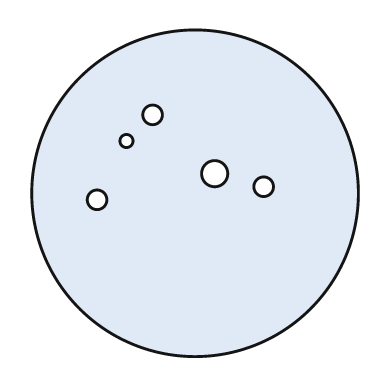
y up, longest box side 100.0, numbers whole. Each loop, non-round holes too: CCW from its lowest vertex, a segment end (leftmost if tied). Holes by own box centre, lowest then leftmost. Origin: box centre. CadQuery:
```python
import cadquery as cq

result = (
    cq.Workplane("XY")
    .moveTo(0.0, 0.0)
    .circle(50.0)
    .moveTo(-30.0, -2.0)
    .circle(3.0)
    .moveTo(21.0, 2.0)
    .circle(3.0)
    .moveTo(6.0, 6.0)
    .circle(4.0)
    .moveTo(-21.0, 16.0)
    .circle(2.0)
    .moveTo(-13.0, 24.0)
    .circle(3.0)
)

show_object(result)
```